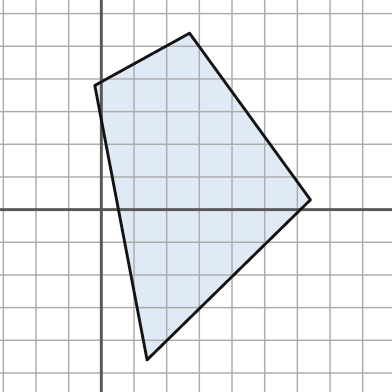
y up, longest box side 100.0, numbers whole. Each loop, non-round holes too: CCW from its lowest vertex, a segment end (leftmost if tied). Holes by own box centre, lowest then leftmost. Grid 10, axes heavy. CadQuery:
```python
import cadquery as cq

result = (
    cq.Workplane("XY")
    .moveTo(14.0, -46.0)
    .lineTo(64.0, 3.0)
    .lineTo(27.0, 54.0)
    .lineTo(-2.0, 38.0)
    .close()
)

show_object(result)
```